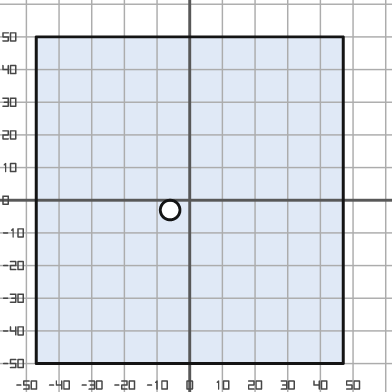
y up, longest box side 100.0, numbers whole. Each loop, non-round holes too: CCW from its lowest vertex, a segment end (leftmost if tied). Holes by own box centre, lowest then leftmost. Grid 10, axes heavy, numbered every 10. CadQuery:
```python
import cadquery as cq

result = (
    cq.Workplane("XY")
    .moveTo(-47.0, -50.0)
    .lineTo(47.0, -50.0)
    .lineTo(47.0, 50.0)
    .lineTo(-47.0, 50.0)
    .close()
    .moveTo(-6.0, -3.0)
    .circle(3.0)
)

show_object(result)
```